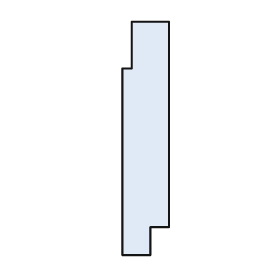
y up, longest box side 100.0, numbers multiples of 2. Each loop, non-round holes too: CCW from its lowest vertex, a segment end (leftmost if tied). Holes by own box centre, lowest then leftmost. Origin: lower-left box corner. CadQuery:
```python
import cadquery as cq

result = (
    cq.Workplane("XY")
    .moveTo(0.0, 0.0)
    .lineTo(12.0, 0.0)
    .lineTo(12.0, 12.0)
    .lineTo(20.0, 12.0)
    .lineTo(20.0, 100.0)
    .lineTo(4.0, 100.0)
    .lineTo(4.0, 80.0)
    .lineTo(0.0, 80.0)
    .close()
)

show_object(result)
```